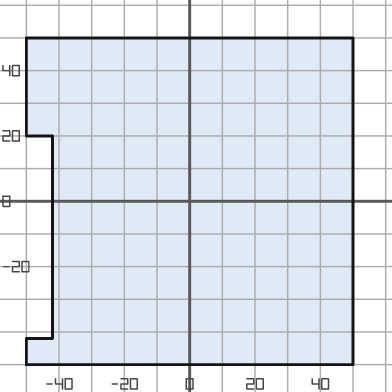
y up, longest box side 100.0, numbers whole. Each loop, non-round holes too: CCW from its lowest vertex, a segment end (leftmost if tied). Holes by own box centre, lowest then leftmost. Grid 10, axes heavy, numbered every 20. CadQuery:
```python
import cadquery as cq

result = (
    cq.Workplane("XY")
    .moveTo(-50.0, -50.0)
    .lineTo(50.0, -50.0)
    .lineTo(50.0, 50.0)
    .lineTo(-50.0, 50.0)
    .lineTo(-50.0, 20.0)
    .lineTo(-42.0, 20.0)
    .lineTo(-42.0, -42.0)
    .lineTo(-50.0, -42.0)
    .close()
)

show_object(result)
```